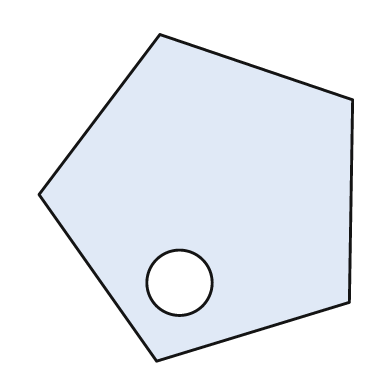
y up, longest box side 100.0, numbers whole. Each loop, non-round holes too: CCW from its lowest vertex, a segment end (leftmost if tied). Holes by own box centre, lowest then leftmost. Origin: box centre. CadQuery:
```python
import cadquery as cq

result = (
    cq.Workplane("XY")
    .moveTo(-12.0, -50.0)
    .lineTo(47.0, -32.0)
    .lineTo(48.0, 30.0)
    .lineTo(-11.0, 50.0)
    .lineTo(-48.0, 1.0)
    .close()
    .moveTo(-5.0, -26.0)
    .circle(10.0)
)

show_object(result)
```